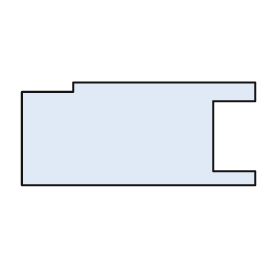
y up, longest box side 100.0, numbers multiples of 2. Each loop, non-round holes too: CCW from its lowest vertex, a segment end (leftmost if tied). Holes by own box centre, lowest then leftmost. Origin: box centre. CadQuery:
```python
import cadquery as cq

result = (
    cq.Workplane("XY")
    .moveTo(-50.0, -22.0)
    .lineTo(50.0, -22.0)
    .lineTo(50.0, -16.0)
    .lineTo(32.0, -16.0)
    .lineTo(32.0, 14.0)
    .lineTo(50.0, 14.0)
    .lineTo(50.0, 22.0)
    .lineTo(-28.0, 22.0)
    .lineTo(-28.0, 18.0)
    .lineTo(-50.0, 18.0)
    .close()
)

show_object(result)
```